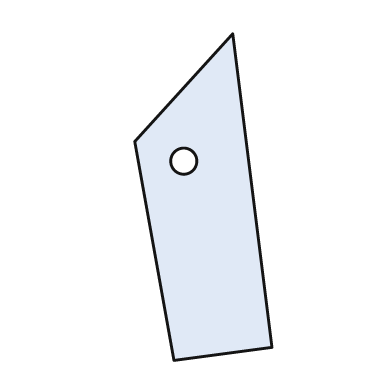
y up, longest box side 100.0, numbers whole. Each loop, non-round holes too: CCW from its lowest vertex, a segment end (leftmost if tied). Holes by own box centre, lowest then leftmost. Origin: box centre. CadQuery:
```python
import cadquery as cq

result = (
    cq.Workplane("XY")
    .moveTo(-9.0, -50.0)
    .lineTo(21.0, -46.0)
    .lineTo(9.0, 50.0)
    .lineTo(-21.0, 17.0)
    .close()
    .moveTo(-6.0, 11.0)
    .circle(4.0)
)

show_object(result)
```